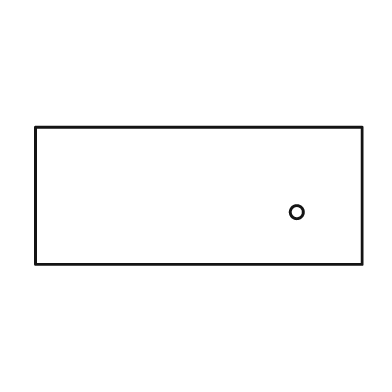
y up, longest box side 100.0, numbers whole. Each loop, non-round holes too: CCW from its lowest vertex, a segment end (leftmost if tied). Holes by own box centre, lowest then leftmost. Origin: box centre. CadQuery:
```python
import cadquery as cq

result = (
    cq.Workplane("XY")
    .moveTo(-50.0, -21.0)
    .lineTo(50.0, -21.0)
    .lineTo(50.0, 21.0)
    .lineTo(-50.0, 21.0)
    .close()
    .moveTo(30.0, -5.0)
    .circle(2.0)
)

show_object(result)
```